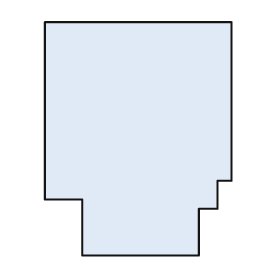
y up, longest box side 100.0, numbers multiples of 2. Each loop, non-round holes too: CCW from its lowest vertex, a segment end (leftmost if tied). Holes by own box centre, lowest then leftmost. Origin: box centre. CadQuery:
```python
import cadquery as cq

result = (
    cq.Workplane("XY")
    .moveTo(-24.0, -50.0)
    .lineTo(26.0, -50.0)
    .lineTo(26.0, -30.0)
    .lineTo(34.0, -30.0)
    .lineTo(34.0, -18.0)
    .lineTo(40.0, -18.0)
    .lineTo(40.0, 50.0)
    .lineTo(-40.0, 50.0)
    .lineTo(-40.0, -26.0)
    .lineTo(-24.0, -26.0)
    .close()
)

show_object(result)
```